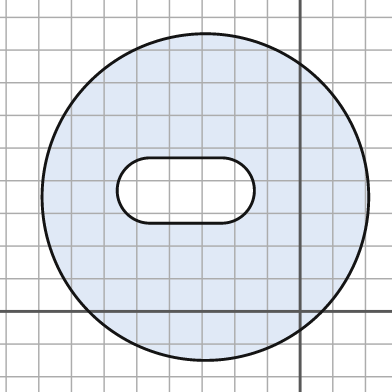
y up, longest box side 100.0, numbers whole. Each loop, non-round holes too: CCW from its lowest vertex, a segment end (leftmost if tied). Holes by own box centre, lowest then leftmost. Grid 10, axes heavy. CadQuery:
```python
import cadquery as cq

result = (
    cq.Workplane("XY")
    .moveTo(-29.0, 35.0)
    .circle(50.0)
    .moveTo(-46.0, 27.0)
    .lineTo(-24.0, 27.0)
    .threePointArc((-14.0, 37.0), (-24.0, 47.0))
    .lineTo(-46.0, 47.0)
    .threePointArc((-56.0, 37.0), (-46.0, 27.0))
    .close()
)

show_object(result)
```